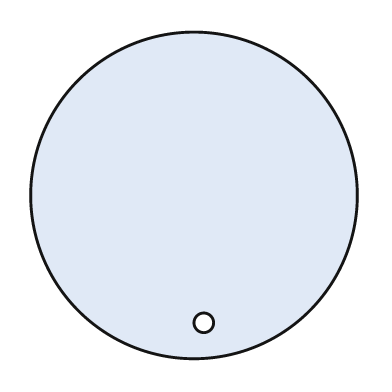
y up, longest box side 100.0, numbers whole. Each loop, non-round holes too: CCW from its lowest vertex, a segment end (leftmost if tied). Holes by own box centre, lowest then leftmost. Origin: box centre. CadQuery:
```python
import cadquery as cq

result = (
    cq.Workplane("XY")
    .moveTo(0.0, 0.0)
    .circle(50.0)
    .moveTo(3.0, -39.0)
    .circle(3.0)
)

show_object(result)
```